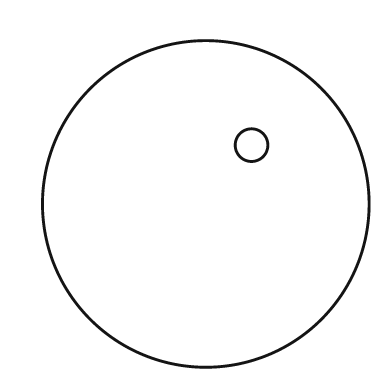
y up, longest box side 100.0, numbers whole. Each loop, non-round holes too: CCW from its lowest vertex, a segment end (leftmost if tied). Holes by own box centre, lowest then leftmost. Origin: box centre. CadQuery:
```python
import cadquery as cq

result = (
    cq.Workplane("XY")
    .moveTo(0.0, 0.0)
    .circle(50.0)
    .moveTo(14.0, 18.0)
    .circle(5.0)
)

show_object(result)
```